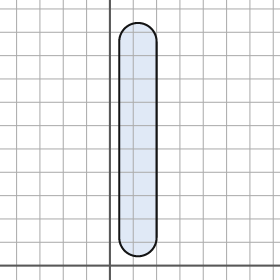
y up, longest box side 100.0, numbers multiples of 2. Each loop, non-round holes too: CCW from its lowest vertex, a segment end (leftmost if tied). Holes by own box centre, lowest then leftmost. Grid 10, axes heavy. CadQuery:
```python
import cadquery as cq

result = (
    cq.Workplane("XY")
    .moveTo(4.0, 12.0)
    .threePointArc((12.0, 4.0), (20.0, 12.0))
    .lineTo(20.0, 96.0)
    .threePointArc((12.0, 104.0), (4.0, 96.0))
    .close()
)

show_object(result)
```